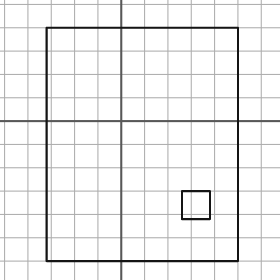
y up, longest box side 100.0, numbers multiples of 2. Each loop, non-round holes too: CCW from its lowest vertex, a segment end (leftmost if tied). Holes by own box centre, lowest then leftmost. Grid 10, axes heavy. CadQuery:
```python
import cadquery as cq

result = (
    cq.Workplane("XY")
    .moveTo(-32.0, -60.0)
    .lineTo(50.0, -60.0)
    .lineTo(50.0, 40.0)
    .lineTo(-32.0, 40.0)
    .close()
    .moveTo(26.0, -42.0)
    .lineTo(38.0, -42.0)
    .lineTo(38.0, -30.0)
    .lineTo(26.0, -30.0)
    .close()
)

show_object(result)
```